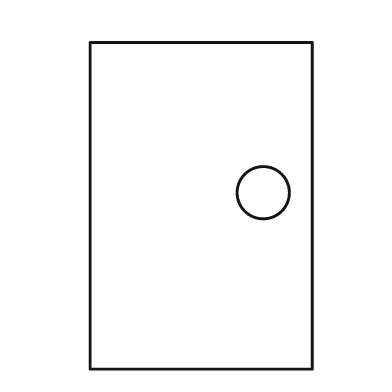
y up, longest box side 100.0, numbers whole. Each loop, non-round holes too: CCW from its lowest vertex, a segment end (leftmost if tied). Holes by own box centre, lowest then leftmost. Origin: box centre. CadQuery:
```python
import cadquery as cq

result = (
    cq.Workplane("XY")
    .moveTo(-34.0, -50.0)
    .lineTo(34.0, -50.0)
    .lineTo(34.0, 50.0)
    .lineTo(-34.0, 50.0)
    .close()
    .moveTo(19.0, 4.0)
    .circle(8.0)
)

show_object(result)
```